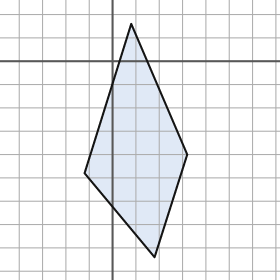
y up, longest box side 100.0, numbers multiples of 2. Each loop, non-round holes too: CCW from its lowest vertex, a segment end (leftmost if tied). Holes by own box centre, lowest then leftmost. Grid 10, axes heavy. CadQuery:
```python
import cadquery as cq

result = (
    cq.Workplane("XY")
    .moveTo(18.0, -84.0)
    .lineTo(32.0, -40.0)
    .lineTo(8.0, 16.0)
    .lineTo(-12.0, -48.0)
    .close()
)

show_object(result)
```